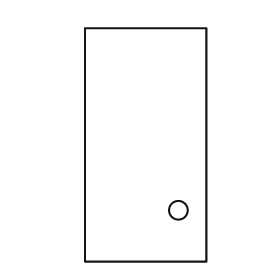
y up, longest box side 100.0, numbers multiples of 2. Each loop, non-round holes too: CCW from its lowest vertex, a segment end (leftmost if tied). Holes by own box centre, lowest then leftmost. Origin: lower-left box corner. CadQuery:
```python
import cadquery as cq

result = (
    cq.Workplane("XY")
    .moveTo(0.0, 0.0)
    .lineTo(52.0, 0.0)
    .lineTo(52.0, 100.0)
    .lineTo(0.0, 100.0)
    .close()
    .moveTo(40.0, 22.0)
    .circle(4.0)
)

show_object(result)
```